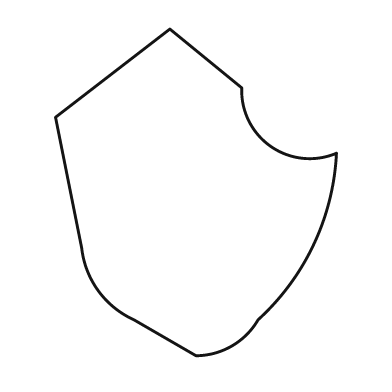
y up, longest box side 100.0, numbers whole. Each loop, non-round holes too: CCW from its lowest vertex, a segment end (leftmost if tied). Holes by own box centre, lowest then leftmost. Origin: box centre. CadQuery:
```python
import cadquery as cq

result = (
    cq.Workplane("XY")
    .moveTo(0.0, -50.0)
    .threePointArc((11.0, -47.0), (19.0, -39.0))
    .threePointArc((36.0, -16.0), (43.0, 12.0))
    .threePointArc((23.0, 14.0), (14.0, 32.0))
    .lineTo(-8.0, 50.0)
    .lineTo(-43.0, 23.0)
    .lineTo(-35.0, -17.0)
    .threePointArc((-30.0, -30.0), (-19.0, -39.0))
    .close()
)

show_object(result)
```